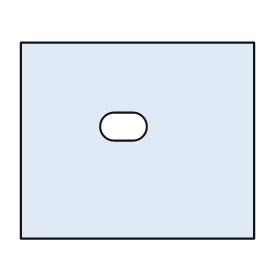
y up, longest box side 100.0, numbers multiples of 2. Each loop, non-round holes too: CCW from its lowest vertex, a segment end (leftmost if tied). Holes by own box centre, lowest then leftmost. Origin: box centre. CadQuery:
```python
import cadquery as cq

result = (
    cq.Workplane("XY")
    .moveTo(-50.0, -42.0)
    .lineTo(50.0, -42.0)
    .lineTo(50.0, 42.0)
    .lineTo(-50.0, 42.0)
    .close()
    .moveTo(-10.0, 0.0)
    .lineTo(-2.0, 0.0)
    .threePointArc((4.0, 6.0), (-2.0, 12.0))
    .lineTo(-10.0, 12.0)
    .threePointArc((-16.0, 6.0), (-10.0, 0.0))
    .close()
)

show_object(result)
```